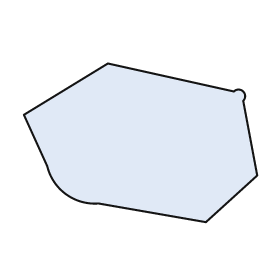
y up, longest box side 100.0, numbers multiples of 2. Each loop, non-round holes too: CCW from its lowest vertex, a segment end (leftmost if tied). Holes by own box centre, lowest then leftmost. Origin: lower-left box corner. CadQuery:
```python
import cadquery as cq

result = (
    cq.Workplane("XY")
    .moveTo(78.0, 0.0)
    .lineTo(100.0, 20.0)
    .lineTo(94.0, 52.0)
    .threePointArc((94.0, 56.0), (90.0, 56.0))
    .lineTo(36.0, 68.0)
    .lineTo(0.0, 46.0)
    .lineTo(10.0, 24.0)
    .threePointArc((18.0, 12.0), (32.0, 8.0))
    .close()
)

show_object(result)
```